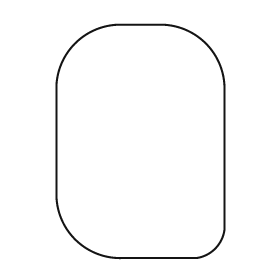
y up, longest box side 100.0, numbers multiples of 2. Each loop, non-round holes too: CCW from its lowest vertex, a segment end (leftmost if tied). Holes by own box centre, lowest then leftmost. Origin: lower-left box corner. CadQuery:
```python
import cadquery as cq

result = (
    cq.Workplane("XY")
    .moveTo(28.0, 0.0)
    .lineTo(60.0, 0.0)
    .threePointArc((68.0, 4.0), (72.0, 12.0))
    .lineTo(72.0, 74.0)
    .threePointArc((64.0, 92.0), (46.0, 100.0))
    .lineTo(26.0, 100.0)
    .threePointArc((8.0, 92.0), (0.0, 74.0))
    .lineTo(0.0, 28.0)
    .threePointArc((8.0, 8.0), (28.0, 0.0))
    .close()
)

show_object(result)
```